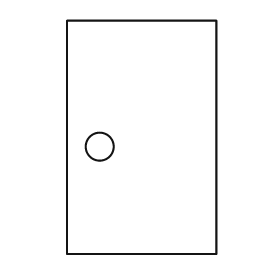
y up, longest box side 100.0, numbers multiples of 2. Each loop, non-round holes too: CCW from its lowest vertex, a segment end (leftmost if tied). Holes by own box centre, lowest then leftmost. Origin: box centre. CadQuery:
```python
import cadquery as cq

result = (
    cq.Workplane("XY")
    .moveTo(-32.0, -50.0)
    .lineTo(32.0, -50.0)
    .lineTo(32.0, 50.0)
    .lineTo(-32.0, 50.0)
    .close()
    .moveTo(-18.0, -4.0)
    .circle(6.0)
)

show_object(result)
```